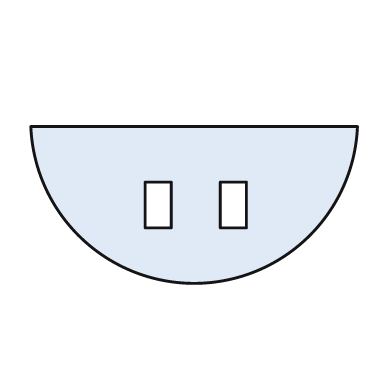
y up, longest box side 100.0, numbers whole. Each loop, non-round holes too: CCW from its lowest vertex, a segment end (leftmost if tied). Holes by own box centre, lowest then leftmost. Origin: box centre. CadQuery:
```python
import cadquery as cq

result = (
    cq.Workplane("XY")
    .moveTo(-50.0, 24.0)
    .threePointArc((0.0, -24.0), (50.0, 24.0))
    .close()
    .moveTo(-15.0, -7.0)
    .lineTo(-7.0, -7.0)
    .lineTo(-7.0, 7.0)
    .lineTo(-15.0, 7.0)
    .close()
    .moveTo(8.0, -7.0)
    .lineTo(16.0, -7.0)
    .lineTo(16.0, 7.0)
    .lineTo(8.0, 7.0)
    .close()
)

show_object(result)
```